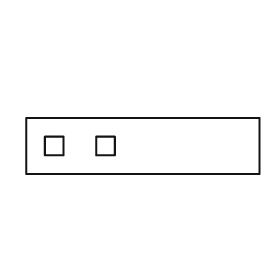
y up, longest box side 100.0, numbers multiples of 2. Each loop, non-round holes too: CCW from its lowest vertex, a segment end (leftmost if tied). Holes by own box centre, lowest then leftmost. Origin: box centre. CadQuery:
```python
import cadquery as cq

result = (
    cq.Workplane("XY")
    .moveTo(-50.0, -12.0)
    .lineTo(50.0, -12.0)
    .lineTo(50.0, 12.0)
    .lineTo(-50.0, 12.0)
    .close()
    .moveTo(-42.0, -4.0)
    .lineTo(-34.0, -4.0)
    .lineTo(-34.0, 4.0)
    .lineTo(-42.0, 4.0)
    .close()
    .moveTo(-20.0, -4.0)
    .lineTo(-12.0, -4.0)
    .lineTo(-12.0, 4.0)
    .lineTo(-20.0, 4.0)
    .close()
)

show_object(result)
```